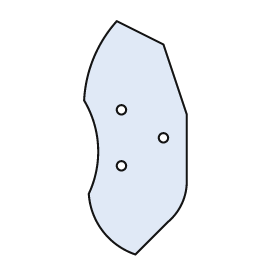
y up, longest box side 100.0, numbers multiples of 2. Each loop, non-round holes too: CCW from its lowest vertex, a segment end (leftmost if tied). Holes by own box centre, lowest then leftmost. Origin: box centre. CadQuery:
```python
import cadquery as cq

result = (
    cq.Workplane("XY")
    .moveTo(0.0, -50.0)
    .lineTo(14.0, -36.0)
    .threePointArc((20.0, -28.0), (22.0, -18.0))
    .lineTo(22.0, 10.0)
    .lineTo(12.0, 40.0)
    .lineTo(-8.0, 50.0)
    .threePointArc((-18.0, 34.0), (-22.0, 16.0))
    .threePointArc((-16.0, -4.0), (-20.0, -24.0))
    .threePointArc((-14.0, -40.0), (0.0, -50.0))
    .close()
    .moveTo(-6.0, -12.0)
    .circle(2.0)
    .moveTo(12.0, 0.0)
    .circle(2.0)
    .moveTo(-6.0, 12.0)
    .circle(2.0)
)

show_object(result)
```